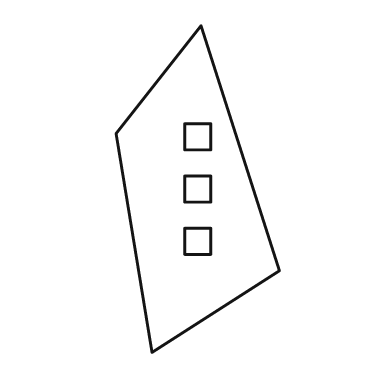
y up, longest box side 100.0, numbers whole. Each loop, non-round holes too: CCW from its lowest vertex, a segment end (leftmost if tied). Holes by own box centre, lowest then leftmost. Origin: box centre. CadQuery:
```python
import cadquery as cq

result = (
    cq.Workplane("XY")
    .moveTo(-14.0, -50.0)
    .lineTo(25.0, -25.0)
    .lineTo(1.0, 50.0)
    .lineTo(-25.0, 17.0)
    .close()
    .moveTo(-4.0, -20.0)
    .lineTo(4.0, -20.0)
    .lineTo(4.0, -12.0)
    .lineTo(-4.0, -12.0)
    .close()
    .moveTo(-4.0, -4.0)
    .lineTo(4.0, -4.0)
    .lineTo(4.0, 4.0)
    .lineTo(-4.0, 4.0)
    .close()
    .moveTo(-4.0, 12.0)
    .lineTo(4.0, 12.0)
    .lineTo(4.0, 20.0)
    .lineTo(-4.0, 20.0)
    .close()
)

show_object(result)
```